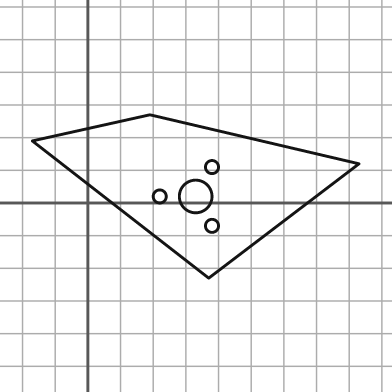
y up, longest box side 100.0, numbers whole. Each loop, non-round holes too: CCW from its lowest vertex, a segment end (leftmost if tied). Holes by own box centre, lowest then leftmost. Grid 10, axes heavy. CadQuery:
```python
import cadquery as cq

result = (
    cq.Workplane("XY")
    .moveTo(37.0, -23.0)
    .lineTo(83.0, 12.0)
    .lineTo(19.0, 27.0)
    .lineTo(-17.0, 19.0)
    .close()
    .moveTo(38.0, -7.0)
    .circle(2.0)
    .moveTo(22.0, 2.0)
    .circle(2.0)
    .moveTo(33.0, 2.0)
    .circle(5.0)
    .moveTo(38.0, 11.0)
    .circle(2.0)
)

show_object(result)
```